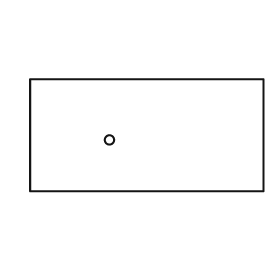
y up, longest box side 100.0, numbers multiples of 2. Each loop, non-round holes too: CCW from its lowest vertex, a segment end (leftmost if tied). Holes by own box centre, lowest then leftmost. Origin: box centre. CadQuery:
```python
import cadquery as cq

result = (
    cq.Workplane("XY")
    .moveTo(-50.0, -24.0)
    .lineTo(50.0, -24.0)
    .lineTo(50.0, 24.0)
    .lineTo(-50.0, 24.0)
    .close()
    .moveTo(-16.0, -2.0)
    .circle(2.0)
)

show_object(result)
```